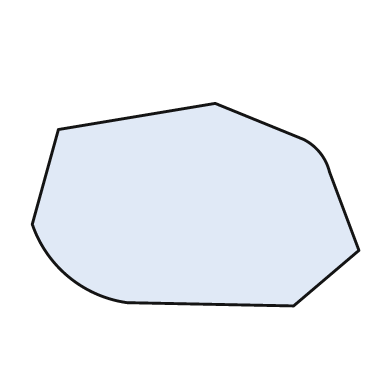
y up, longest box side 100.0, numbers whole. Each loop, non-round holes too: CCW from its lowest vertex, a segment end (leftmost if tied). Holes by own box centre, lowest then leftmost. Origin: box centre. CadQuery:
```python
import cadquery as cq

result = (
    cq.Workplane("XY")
    .moveTo(30.0, -31.0)
    .lineTo(50.0, -14.0)
    .lineTo(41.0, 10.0)
    .threePointArc((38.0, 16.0), (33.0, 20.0))
    .lineTo(6.0, 31.0)
    .lineTo(-42.0, 23.0)
    .lineTo(-50.0, -6.0)
    .threePointArc((-39.0, -22.0), (-21.0, -30.0))
    .close()
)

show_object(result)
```